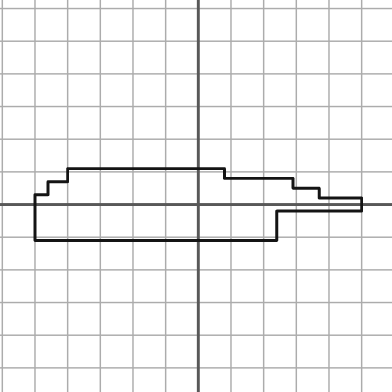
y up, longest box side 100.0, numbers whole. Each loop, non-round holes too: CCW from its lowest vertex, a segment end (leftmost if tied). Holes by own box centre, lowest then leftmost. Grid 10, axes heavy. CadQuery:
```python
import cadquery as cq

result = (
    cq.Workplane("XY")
    .moveTo(-50.0, -11.0)
    .lineTo(24.0, -11.0)
    .lineTo(24.0, -2.0)
    .lineTo(50.0, -2.0)
    .lineTo(50.0, 2.0)
    .lineTo(37.0, 2.0)
    .lineTo(37.0, 5.0)
    .lineTo(29.0, 5.0)
    .lineTo(29.0, 8.0)
    .lineTo(8.0, 8.0)
    .lineTo(8.0, 11.0)
    .lineTo(-40.0, 11.0)
    .lineTo(-40.0, 7.0)
    .lineTo(-46.0, 7.0)
    .lineTo(-46.0, 3.0)
    .lineTo(-50.0, 3.0)
    .close()
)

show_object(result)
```